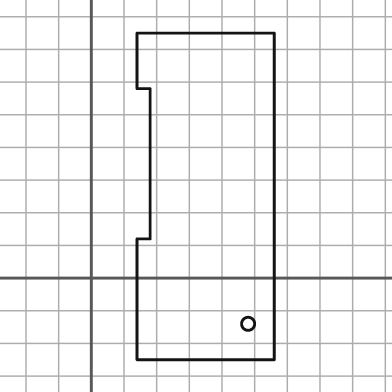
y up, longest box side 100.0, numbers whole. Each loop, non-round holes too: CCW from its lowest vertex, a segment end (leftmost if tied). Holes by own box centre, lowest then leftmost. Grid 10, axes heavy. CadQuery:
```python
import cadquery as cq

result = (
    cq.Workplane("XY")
    .moveTo(14.0, -25.0)
    .lineTo(56.0, -25.0)
    .lineTo(56.0, 75.0)
    .lineTo(14.0, 75.0)
    .lineTo(14.0, 58.0)
    .lineTo(18.0, 58.0)
    .lineTo(18.0, 12.0)
    .lineTo(14.0, 12.0)
    .close()
    .moveTo(48.0, -14.0)
    .circle(2.0)
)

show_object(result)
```